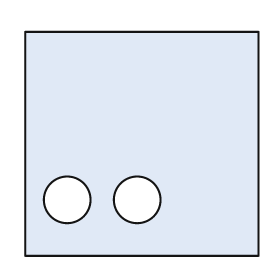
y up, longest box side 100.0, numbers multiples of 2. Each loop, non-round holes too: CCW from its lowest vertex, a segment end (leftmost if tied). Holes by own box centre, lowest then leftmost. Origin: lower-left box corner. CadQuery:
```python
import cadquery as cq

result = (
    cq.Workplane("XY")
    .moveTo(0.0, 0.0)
    .lineTo(100.0, 0.0)
    .lineTo(100.0, 96.0)
    .lineTo(0.0, 96.0)
    .close()
    .moveTo(18.0, 24.0)
    .circle(10.0)
    .moveTo(48.0, 24.0)
    .circle(10.0)
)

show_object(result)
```